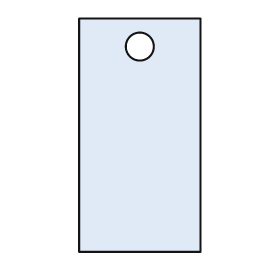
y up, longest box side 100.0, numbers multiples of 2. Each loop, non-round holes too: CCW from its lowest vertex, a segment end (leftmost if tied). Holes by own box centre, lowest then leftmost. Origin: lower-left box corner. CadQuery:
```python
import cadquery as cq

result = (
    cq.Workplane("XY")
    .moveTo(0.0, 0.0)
    .lineTo(52.0, 0.0)
    .lineTo(52.0, 100.0)
    .lineTo(0.0, 100.0)
    .close()
    .moveTo(26.0, 88.0)
    .circle(6.0)
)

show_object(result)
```